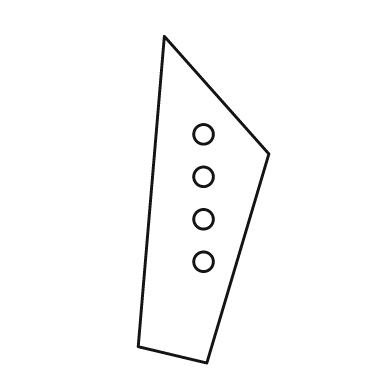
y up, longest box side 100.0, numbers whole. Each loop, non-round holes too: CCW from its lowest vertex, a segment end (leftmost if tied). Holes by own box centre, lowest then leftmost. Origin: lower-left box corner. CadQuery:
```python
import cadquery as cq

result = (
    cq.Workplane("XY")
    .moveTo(21.0, 0.0)
    .lineTo(40.0, 64.0)
    .lineTo(8.0, 100.0)
    .lineTo(0.0, 5.0)
    .close()
    .moveTo(20.0, 31.0)
    .circle(3.0)
    .moveTo(20.0, 44.0)
    .circle(3.0)
    .moveTo(20.0, 57.0)
    .circle(3.0)
    .moveTo(20.0, 70.0)
    .circle(3.0)
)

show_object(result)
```